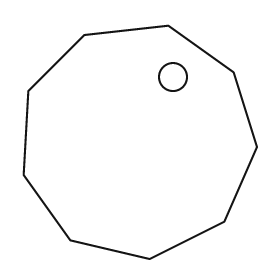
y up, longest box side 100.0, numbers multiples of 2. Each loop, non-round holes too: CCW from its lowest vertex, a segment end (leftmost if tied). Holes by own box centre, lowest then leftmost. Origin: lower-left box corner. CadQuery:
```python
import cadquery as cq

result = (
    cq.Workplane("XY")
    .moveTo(54.0, 0.0)
    .lineTo(86.0, 16.0)
    .lineTo(100.0, 48.0)
    .lineTo(90.0, 80.0)
    .lineTo(62.0, 100.0)
    .lineTo(26.0, 96.0)
    .lineTo(2.0, 72.0)
    .lineTo(0.0, 36.0)
    .lineTo(20.0, 8.0)
    .close()
    .moveTo(64.0, 78.0)
    .circle(6.0)
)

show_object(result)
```